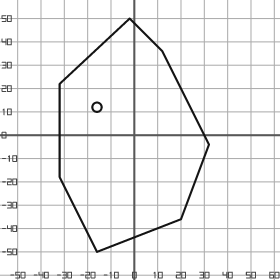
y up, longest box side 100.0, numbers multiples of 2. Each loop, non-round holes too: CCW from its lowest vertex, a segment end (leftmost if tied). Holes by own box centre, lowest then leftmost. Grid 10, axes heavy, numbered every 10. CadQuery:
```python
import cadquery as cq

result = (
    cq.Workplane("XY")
    .moveTo(-16.0, -50.0)
    .lineTo(20.0, -36.0)
    .lineTo(32.0, -4.0)
    .lineTo(12.0, 36.0)
    .lineTo(-2.0, 50.0)
    .lineTo(-32.0, 22.0)
    .lineTo(-32.0, -18.0)
    .close()
    .moveTo(-16.0, 12.0)
    .circle(2.0)
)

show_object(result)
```